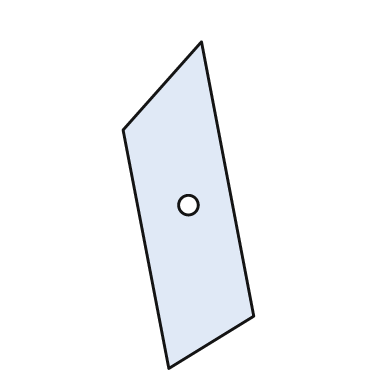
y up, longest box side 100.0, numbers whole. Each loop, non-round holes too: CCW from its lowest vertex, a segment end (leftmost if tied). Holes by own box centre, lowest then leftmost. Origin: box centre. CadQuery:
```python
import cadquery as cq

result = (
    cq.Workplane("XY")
    .moveTo(-6.0, -50.0)
    .lineTo(20.0, -34.0)
    .lineTo(4.0, 50.0)
    .lineTo(-20.0, 23.0)
    .close()
    .moveTo(0.0, 0.0)
    .circle(3.0)
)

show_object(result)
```